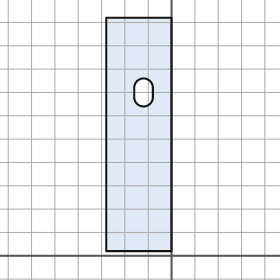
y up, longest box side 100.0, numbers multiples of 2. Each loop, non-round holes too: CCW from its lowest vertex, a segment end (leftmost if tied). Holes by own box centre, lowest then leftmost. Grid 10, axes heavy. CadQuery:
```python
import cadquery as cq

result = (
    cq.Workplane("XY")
    .moveTo(-28.0, 2.0)
    .lineTo(0.0, 2.0)
    .lineTo(0.0, 102.0)
    .lineTo(-28.0, 102.0)
    .close()
    .moveTo(-16.0, 68.0)
    .threePointArc((-12.0, 64.0), (-8.0, 68.0))
    .lineTo(-8.0, 72.0)
    .threePointArc((-12.0, 76.0), (-16.0, 72.0))
    .close()
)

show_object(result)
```